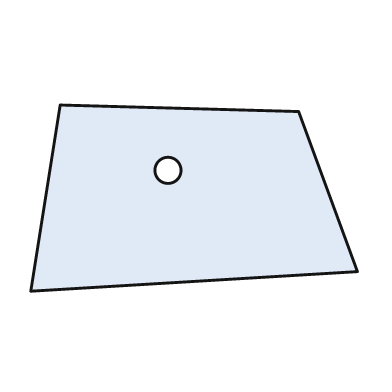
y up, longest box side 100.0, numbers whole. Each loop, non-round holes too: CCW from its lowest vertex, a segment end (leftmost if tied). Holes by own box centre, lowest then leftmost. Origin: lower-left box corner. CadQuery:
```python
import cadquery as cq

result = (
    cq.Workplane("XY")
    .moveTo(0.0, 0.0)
    .lineTo(100.0, 6.0)
    .lineTo(82.0, 55.0)
    .lineTo(9.0, 57.0)
    .close()
    .moveTo(42.0, 37.0)
    .circle(4.0)
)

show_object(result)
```